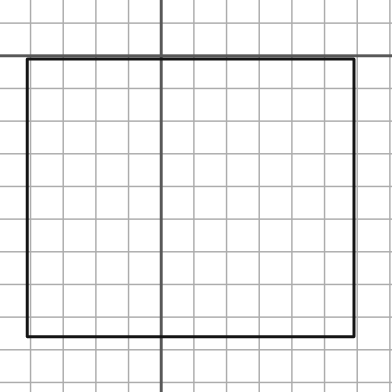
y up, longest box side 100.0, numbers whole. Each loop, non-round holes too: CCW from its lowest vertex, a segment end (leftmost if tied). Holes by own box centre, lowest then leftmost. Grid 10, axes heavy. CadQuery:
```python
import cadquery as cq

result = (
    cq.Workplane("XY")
    .moveTo(-41.0, -86.0)
    .lineTo(59.0, -86.0)
    .lineTo(59.0, -1.0)
    .lineTo(-41.0, -1.0)
    .close()
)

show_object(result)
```